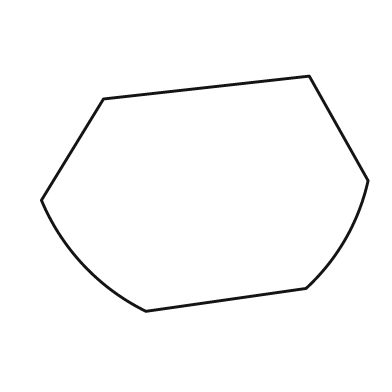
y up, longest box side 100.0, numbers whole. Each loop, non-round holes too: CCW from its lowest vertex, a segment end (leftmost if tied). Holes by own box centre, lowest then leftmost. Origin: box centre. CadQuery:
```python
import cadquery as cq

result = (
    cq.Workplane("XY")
    .moveTo(-18.0, -36.0)
    .lineTo(31.0, -29.0)
    .threePointArc((43.0, -14.0), (50.0, 4.0))
    .lineTo(32.0, 36.0)
    .lineTo(-31.0, 29.0)
    .lineTo(-50.0, -2.0)
    .threePointArc((-37.0, -22.0), (-18.0, -36.0))
    .close()
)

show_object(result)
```